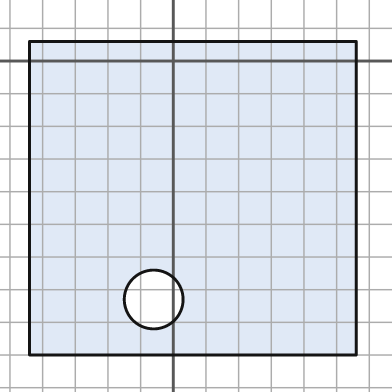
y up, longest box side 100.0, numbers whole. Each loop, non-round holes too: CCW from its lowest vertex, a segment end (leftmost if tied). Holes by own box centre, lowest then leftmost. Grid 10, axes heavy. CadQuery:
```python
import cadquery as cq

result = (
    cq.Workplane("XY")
    .moveTo(-44.0, -90.0)
    .lineTo(56.0, -90.0)
    .lineTo(56.0, 6.0)
    .lineTo(-44.0, 6.0)
    .close()
    .moveTo(-6.0, -73.0)
    .circle(9.0)
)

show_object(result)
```